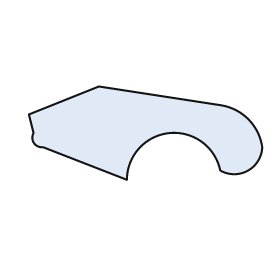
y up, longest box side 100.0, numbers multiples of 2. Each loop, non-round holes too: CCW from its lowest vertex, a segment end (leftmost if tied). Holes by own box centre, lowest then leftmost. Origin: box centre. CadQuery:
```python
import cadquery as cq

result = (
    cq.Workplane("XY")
    .moveTo(-8.0, -20.0)
    .threePointArc((10.0, 0.0), (32.0, -16.0))
    .threePointArc((44.0, -16.0), (50.0, -6.0))
    .threePointArc((44.0, 6.0), (32.0, 12.0))
    .lineTo(-20.0, 20.0)
    .lineTo(-50.0, 8.0)
    .lineTo(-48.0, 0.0)
    .threePointArc((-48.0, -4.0), (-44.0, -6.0))
    .close()
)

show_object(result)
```